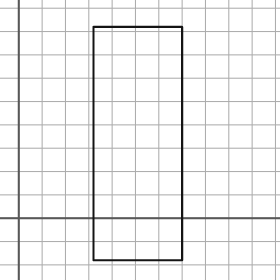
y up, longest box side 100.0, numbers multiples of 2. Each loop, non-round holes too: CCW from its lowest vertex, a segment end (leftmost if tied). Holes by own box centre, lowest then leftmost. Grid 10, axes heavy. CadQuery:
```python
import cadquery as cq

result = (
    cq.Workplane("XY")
    .moveTo(32.0, -18.0)
    .lineTo(70.0, -18.0)
    .lineTo(70.0, 82.0)
    .lineTo(32.0, 82.0)
    .close()
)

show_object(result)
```